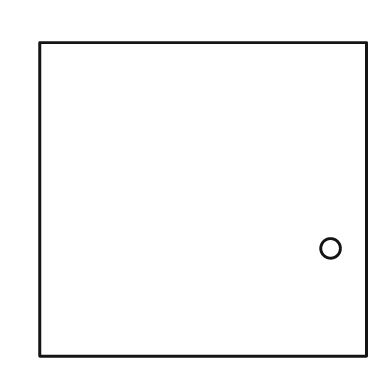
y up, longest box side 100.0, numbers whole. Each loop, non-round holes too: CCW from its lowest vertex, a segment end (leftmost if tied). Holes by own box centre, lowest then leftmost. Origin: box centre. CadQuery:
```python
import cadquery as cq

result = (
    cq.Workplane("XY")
    .moveTo(-50.0, -48.0)
    .lineTo(50.0, -48.0)
    .lineTo(50.0, 48.0)
    .lineTo(-50.0, 48.0)
    .close()
    .moveTo(39.0, -15.0)
    .circle(3.0)
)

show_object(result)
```